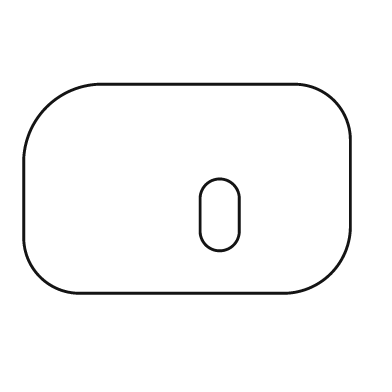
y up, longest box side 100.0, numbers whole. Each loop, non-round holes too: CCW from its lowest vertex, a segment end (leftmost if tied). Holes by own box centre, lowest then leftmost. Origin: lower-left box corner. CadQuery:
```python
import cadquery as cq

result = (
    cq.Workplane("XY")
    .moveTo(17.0, 0.0)
    .lineTo(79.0, 0.0)
    .threePointArc((94.0, 6.0), (100.0, 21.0))
    .lineTo(100.0, 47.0)
    .threePointArc((95.0, 59.0), (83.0, 64.0))
    .lineTo(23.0, 64.0)
    .threePointArc((7.0, 57.0), (0.0, 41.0))
    .lineTo(0.0, 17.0)
    .threePointArc((5.0, 5.0), (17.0, 0.0))
    .close()
    .moveTo(54.0, 19.0)
    .threePointArc((60.0, 13.0), (66.0, 19.0))
    .lineTo(66.0, 29.0)
    .threePointArc((60.0, 35.0), (54.0, 29.0))
    .close()
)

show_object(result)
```